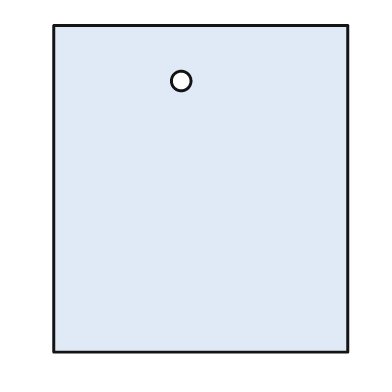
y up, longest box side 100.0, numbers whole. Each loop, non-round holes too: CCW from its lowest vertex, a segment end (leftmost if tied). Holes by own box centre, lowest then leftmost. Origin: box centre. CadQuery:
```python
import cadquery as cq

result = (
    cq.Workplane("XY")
    .moveTo(-45.0, -50.0)
    .lineTo(45.0, -50.0)
    .lineTo(45.0, 50.0)
    .lineTo(-45.0, 50.0)
    .close()
    .moveTo(-6.0, 33.0)
    .circle(3.0)
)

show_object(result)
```